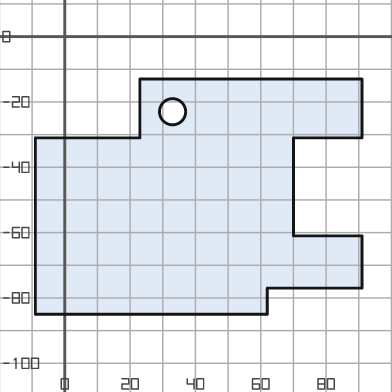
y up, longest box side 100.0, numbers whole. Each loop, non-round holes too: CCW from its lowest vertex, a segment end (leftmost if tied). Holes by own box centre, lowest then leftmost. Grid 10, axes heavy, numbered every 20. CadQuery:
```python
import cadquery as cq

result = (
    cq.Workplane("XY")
    .moveTo(-9.0, -85.0)
    .lineTo(62.0, -85.0)
    .lineTo(62.0, -77.0)
    .lineTo(91.0, -77.0)
    .lineTo(91.0, -61.0)
    .lineTo(70.0, -61.0)
    .lineTo(70.0, -31.0)
    .lineTo(91.0, -31.0)
    .lineTo(91.0, -13.0)
    .lineTo(23.0, -13.0)
    .lineTo(23.0, -31.0)
    .lineTo(-9.0, -31.0)
    .close()
    .moveTo(33.0, -23.0)
    .circle(4.0)
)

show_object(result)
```